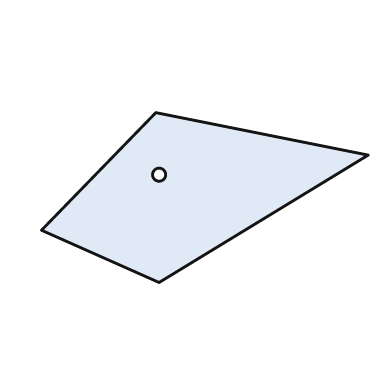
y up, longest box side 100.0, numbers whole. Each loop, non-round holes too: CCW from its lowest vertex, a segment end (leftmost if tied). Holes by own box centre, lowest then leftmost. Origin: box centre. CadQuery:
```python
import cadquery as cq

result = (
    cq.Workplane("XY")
    .moveTo(-14.0, -26.0)
    .lineTo(50.0, 13.0)
    .lineTo(-15.0, 26.0)
    .lineTo(-50.0, -10.0)
    .close()
    .moveTo(-14.0, 7.0)
    .circle(2.0)
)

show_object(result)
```